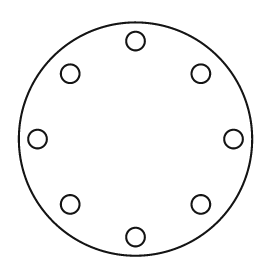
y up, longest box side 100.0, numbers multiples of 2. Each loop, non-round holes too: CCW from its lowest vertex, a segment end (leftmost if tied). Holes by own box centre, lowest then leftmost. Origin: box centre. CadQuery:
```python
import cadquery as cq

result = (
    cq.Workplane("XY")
    .moveTo(0.0, 0.0)
    .circle(50.0)
    .moveTo(0.0, -42.0)
    .circle(4.0)
    .moveTo(-28.0, -28.0)
    .circle(4.0)
    .moveTo(28.0, -28.0)
    .circle(4.0)
    .moveTo(-42.0, 0.0)
    .circle(4.0)
    .moveTo(42.0, 0.0)
    .circle(4.0)
    .moveTo(-28.0, 28.0)
    .circle(4.0)
    .moveTo(28.0, 28.0)
    .circle(4.0)
    .moveTo(0.0, 42.0)
    .circle(4.0)
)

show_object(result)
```